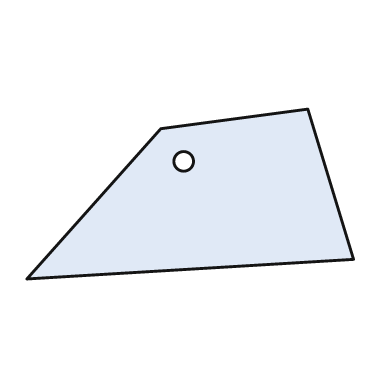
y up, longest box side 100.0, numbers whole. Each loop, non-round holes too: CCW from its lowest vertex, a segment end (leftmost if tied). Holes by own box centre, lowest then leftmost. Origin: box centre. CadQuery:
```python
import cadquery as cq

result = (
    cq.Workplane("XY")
    .moveTo(-50.0, -26.0)
    .lineTo(50.0, -20.0)
    .lineTo(36.0, 26.0)
    .lineTo(-9.0, 20.0)
    .close()
    .moveTo(-2.0, 10.0)
    .circle(3.0)
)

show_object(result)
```